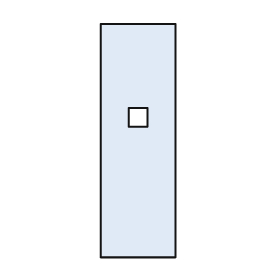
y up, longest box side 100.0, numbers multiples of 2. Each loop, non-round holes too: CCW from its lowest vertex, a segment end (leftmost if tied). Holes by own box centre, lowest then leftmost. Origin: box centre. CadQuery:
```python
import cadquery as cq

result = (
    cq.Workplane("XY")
    .moveTo(-16.0, -50.0)
    .lineTo(16.0, -50.0)
    .lineTo(16.0, 50.0)
    .lineTo(-16.0, 50.0)
    .close()
    .moveTo(-4.0, 6.0)
    .lineTo(4.0, 6.0)
    .lineTo(4.0, 14.0)
    .lineTo(-4.0, 14.0)
    .close()
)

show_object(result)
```